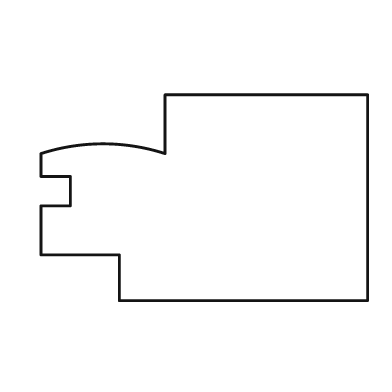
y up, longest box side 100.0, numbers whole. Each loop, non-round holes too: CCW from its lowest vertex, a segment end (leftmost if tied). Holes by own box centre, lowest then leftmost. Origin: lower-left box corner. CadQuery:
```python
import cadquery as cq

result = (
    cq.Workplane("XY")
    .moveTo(24.0, 0.0)
    .lineTo(100.0, 0.0)
    .lineTo(100.0, 63.0)
    .lineTo(38.0, 63.0)
    .lineTo(38.0, 45.0)
    .threePointArc((19.0, 48.0), (0.0, 45.0))
    .lineTo(0.0, 38.0)
    .lineTo(9.0, 38.0)
    .lineTo(9.0, 29.0)
    .lineTo(0.0, 29.0)
    .lineTo(0.0, 14.0)
    .lineTo(24.0, 14.0)
    .close()
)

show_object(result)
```